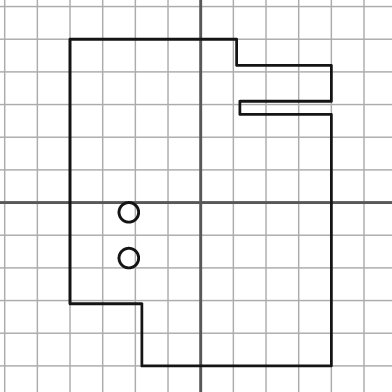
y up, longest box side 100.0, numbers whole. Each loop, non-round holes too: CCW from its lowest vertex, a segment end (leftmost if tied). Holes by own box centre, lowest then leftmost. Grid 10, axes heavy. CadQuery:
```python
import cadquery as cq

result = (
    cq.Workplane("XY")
    .moveTo(-18.0, -50.0)
    .lineTo(40.0, -50.0)
    .lineTo(40.0, 27.0)
    .lineTo(12.0, 27.0)
    .lineTo(12.0, 31.0)
    .lineTo(40.0, 31.0)
    .lineTo(40.0, 42.0)
    .lineTo(11.0, 42.0)
    .lineTo(11.0, 50.0)
    .lineTo(-40.0, 50.0)
    .lineTo(-40.0, -31.0)
    .lineTo(-18.0, -31.0)
    .close()
    .moveTo(-22.0, -17.0)
    .circle(3.0)
    .moveTo(-22.0, -3.0)
    .circle(3.0)
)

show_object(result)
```